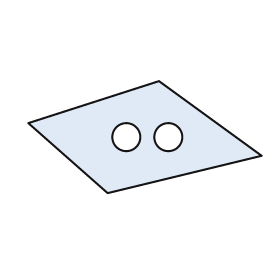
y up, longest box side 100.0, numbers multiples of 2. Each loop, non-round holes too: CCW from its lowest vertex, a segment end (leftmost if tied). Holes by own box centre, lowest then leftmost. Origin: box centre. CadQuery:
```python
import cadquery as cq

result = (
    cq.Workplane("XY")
    .moveTo(-16.0, -24.0)
    .lineTo(50.0, -8.0)
    .lineTo(6.0, 24.0)
    .lineTo(-50.0, 6.0)
    .close()
    .moveTo(-8.0, 0.0)
    .circle(6.0)
    .moveTo(10.0, 0.0)
    .circle(6.0)
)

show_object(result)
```